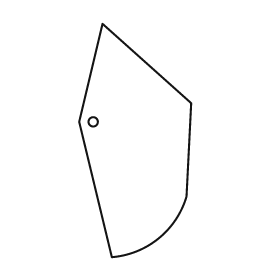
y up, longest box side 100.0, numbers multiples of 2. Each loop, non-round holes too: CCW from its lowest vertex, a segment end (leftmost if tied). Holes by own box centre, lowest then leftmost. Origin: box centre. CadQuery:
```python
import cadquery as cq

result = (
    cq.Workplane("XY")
    .moveTo(-10.0, -50.0)
    .threePointArc((10.0, -42.0), (22.0, -24.0))
    .lineTo(24.0, 16.0)
    .lineTo(-14.0, 50.0)
    .lineTo(-24.0, 8.0)
    .close()
    .moveTo(-18.0, 8.0)
    .circle(2.0)
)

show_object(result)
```